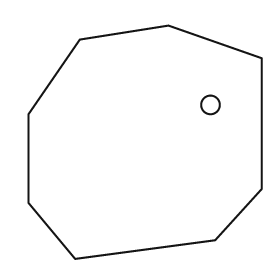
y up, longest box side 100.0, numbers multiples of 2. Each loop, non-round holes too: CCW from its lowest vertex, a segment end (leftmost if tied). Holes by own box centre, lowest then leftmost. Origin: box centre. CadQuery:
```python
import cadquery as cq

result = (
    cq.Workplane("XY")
    .moveTo(-30.0, -50.0)
    .lineTo(30.0, -42.0)
    .lineTo(50.0, -20.0)
    .lineTo(50.0, 36.0)
    .lineTo(10.0, 50.0)
    .lineTo(-28.0, 44.0)
    .lineTo(-50.0, 12.0)
    .lineTo(-50.0, -26.0)
    .close()
    .moveTo(28.0, 16.0)
    .circle(4.0)
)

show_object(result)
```